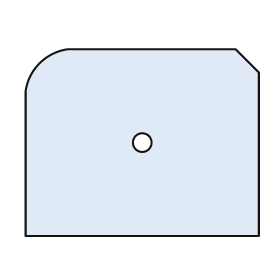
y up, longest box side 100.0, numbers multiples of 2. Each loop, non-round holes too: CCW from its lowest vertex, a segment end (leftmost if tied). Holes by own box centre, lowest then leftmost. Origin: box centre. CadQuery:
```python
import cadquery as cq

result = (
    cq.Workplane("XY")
    .moveTo(-50.0, -40.0)
    .lineTo(50.0, -40.0)
    .lineTo(50.0, 30.0)
    .lineTo(40.0, 40.0)
    .lineTo(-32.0, 40.0)
    .threePointArc((-44.0, 34.0), (-50.0, 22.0))
    .close()
    .moveTo(0.0, 0.0)
    .circle(4.0)
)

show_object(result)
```